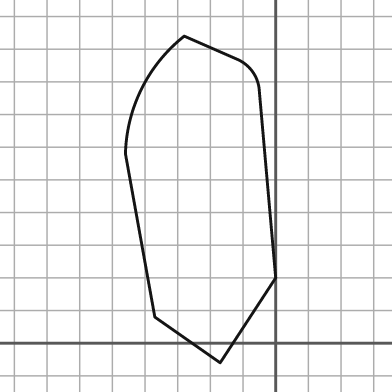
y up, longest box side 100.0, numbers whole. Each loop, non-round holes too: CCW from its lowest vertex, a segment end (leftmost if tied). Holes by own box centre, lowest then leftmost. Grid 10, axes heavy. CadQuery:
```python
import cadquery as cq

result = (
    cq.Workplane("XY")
    .moveTo(-17.0, -6.0)
    .lineTo(0.0, 20.0)
    .lineTo(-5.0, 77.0)
    .threePointArc((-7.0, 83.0), (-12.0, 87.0))
    .lineTo(-28.0, 94.0)
    .threePointArc((-41.0, 78.0), (-46.0, 58.0))
    .lineTo(-37.0, 8.0)
    .close()
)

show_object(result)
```